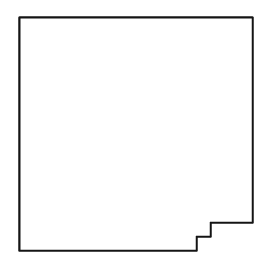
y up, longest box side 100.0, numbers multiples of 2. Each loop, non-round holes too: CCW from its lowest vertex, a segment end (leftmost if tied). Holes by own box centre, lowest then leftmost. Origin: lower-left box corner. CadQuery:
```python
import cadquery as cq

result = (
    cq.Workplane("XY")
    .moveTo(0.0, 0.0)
    .lineTo(76.0, 0.0)
    .lineTo(76.0, 6.0)
    .lineTo(82.0, 6.0)
    .lineTo(82.0, 12.0)
    .lineTo(100.0, 12.0)
    .lineTo(100.0, 100.0)
    .lineTo(0.0, 100.0)
    .close()
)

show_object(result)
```